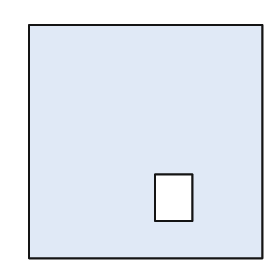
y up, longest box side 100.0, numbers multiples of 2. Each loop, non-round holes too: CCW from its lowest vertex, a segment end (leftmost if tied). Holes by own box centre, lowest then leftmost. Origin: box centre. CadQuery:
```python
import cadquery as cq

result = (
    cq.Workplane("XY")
    .moveTo(-50.0, -50.0)
    .lineTo(50.0, -50.0)
    .lineTo(50.0, 50.0)
    .lineTo(-50.0, 50.0)
    .close()
    .moveTo(4.0, -34.0)
    .lineTo(20.0, -34.0)
    .lineTo(20.0, -14.0)
    .lineTo(4.0, -14.0)
    .close()
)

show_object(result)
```